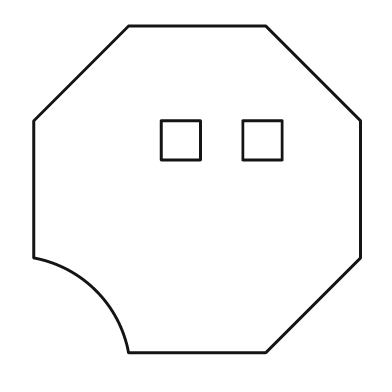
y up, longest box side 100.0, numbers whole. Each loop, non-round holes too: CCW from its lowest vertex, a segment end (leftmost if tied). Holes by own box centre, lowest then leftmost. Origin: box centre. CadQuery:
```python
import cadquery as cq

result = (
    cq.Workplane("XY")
    .moveTo(-21.0, -50.0)
    .lineTo(21.0, -50.0)
    .lineTo(50.0, -21.0)
    .lineTo(50.0, 21.0)
    .lineTo(21.0, 50.0)
    .lineTo(-21.0, 50.0)
    .lineTo(-50.0, 21.0)
    .lineTo(-50.0, -21.0)
    .threePointArc((-31.0, -31.0), (-21.0, -50.0))
    .close()
    .moveTo(-11.0, 9.0)
    .lineTo(1.0, 9.0)
    .lineTo(1.0, 21.0)
    .lineTo(-11.0, 21.0)
    .close()
    .moveTo(14.0, 9.0)
    .lineTo(26.0, 9.0)
    .lineTo(26.0, 21.0)
    .lineTo(14.0, 21.0)
    .close()
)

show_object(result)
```